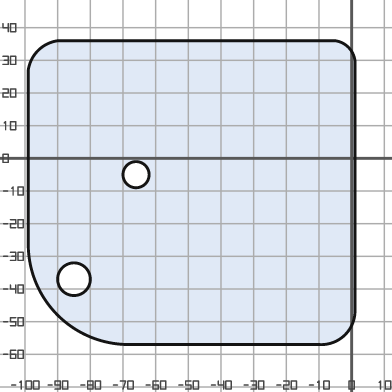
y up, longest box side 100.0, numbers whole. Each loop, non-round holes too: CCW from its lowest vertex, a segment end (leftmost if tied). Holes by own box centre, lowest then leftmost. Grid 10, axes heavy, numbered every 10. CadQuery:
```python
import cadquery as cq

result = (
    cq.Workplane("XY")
    .moveTo(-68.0, -57.0)
    .lineTo(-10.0, -57.0)
    .threePointArc((-2.0, -54.0), (1.0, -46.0))
    .lineTo(1.0, 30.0)
    .threePointArc((-1.0, 34.0), (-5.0, 36.0))
    .lineTo(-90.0, 36.0)
    .threePointArc((-96.0, 33.0), (-99.0, 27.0))
    .lineTo(-99.0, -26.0)
    .threePointArc((-90.0, -48.0), (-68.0, -57.0))
    .close()
    .moveTo(-85.0, -37.0)
    .circle(5.0)
    .moveTo(-66.0, -5.0)
    .circle(4.0)
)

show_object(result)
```